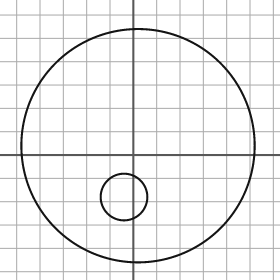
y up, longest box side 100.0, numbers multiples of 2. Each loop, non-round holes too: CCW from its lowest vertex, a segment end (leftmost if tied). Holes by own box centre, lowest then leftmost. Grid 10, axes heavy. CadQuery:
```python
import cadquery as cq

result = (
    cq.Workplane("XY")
    .moveTo(2.0, 4.0)
    .circle(50.0)
    .moveTo(-4.0, -18.0)
    .circle(10.0)
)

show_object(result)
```